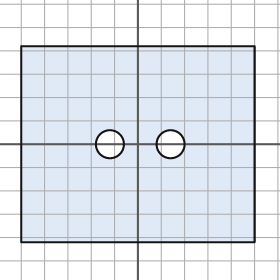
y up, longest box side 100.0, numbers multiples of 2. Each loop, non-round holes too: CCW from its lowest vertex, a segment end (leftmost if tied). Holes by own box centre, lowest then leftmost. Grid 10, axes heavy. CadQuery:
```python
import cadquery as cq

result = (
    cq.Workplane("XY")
    .moveTo(-50.0, -42.0)
    .lineTo(50.0, -42.0)
    .lineTo(50.0, 42.0)
    .lineTo(-50.0, 42.0)
    .close()
    .moveTo(-12.0, 0.0)
    .circle(6.0)
    .moveTo(14.0, 0.0)
    .circle(6.0)
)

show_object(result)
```